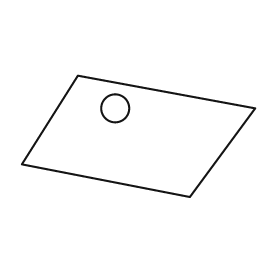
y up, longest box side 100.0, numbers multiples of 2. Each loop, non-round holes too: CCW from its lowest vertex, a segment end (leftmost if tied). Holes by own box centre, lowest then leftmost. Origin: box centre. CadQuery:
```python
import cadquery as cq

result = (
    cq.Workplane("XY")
    .moveTo(22.0, -26.0)
    .lineTo(50.0, 12.0)
    .lineTo(-26.0, 26.0)
    .lineTo(-50.0, -12.0)
    .close()
    .moveTo(-10.0, 12.0)
    .circle(6.0)
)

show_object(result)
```